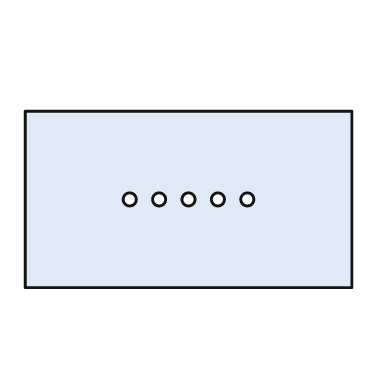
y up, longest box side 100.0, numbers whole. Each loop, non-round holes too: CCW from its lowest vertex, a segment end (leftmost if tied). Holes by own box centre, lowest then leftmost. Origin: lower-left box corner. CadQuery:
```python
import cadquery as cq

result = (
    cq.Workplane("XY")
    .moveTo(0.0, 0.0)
    .lineTo(100.0, 0.0)
    .lineTo(100.0, 54.0)
    .lineTo(0.0, 54.0)
    .close()
    .moveTo(32.0, 27.0)
    .circle(2.0)
    .moveTo(41.0, 27.0)
    .circle(2.0)
    .moveTo(50.0, 27.0)
    .circle(2.0)
    .moveTo(59.0, 27.0)
    .circle(2.0)
    .moveTo(68.0, 27.0)
    .circle(2.0)
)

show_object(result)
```